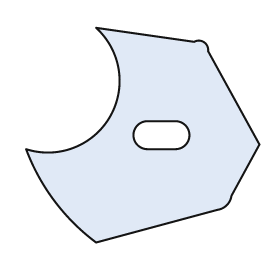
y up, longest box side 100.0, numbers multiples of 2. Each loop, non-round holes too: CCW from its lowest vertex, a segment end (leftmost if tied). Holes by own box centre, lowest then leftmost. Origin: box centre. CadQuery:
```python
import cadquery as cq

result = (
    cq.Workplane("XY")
    .moveTo(-20.0, -46.0)
    .lineTo(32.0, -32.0)
    .threePointArc((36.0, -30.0), (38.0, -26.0))
    .lineTo(50.0, -4.0)
    .lineTo(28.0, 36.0)
    .threePointArc((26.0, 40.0), (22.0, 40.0))
    .lineTo(-20.0, 46.0)
    .threePointArc((-14.0, 8.0), (-50.0, -6.0))
    .threePointArc((-38.0, -28.0), (-20.0, -46.0))
    .close()
    .moveTo(2.0, -6.0)
    .lineTo(14.0, -6.0)
    .threePointArc((20.0, 0.0), (14.0, 6.0))
    .lineTo(2.0, 6.0)
    .threePointArc((-4.0, 0.0), (2.0, -6.0))
    .close()
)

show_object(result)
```